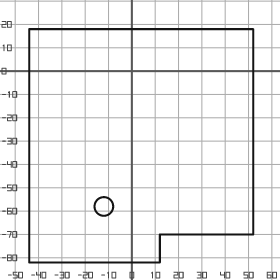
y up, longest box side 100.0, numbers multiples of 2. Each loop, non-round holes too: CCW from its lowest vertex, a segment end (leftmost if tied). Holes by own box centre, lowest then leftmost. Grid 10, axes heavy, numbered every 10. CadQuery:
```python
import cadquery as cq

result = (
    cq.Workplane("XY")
    .moveTo(-44.0, -82.0)
    .lineTo(12.0, -82.0)
    .lineTo(12.0, -70.0)
    .lineTo(52.0, -70.0)
    .lineTo(52.0, 18.0)
    .lineTo(-44.0, 18.0)
    .close()
    .moveTo(-12.0, -58.0)
    .circle(4.0)
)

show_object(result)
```